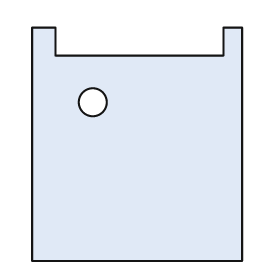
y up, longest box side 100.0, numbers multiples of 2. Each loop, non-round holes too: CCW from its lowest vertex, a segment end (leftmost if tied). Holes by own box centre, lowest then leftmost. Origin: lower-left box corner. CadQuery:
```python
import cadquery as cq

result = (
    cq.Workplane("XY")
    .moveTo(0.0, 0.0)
    .lineTo(90.0, 0.0)
    .lineTo(90.0, 100.0)
    .lineTo(82.0, 100.0)
    .lineTo(82.0, 88.0)
    .lineTo(10.0, 88.0)
    .lineTo(10.0, 100.0)
    .lineTo(0.0, 100.0)
    .close()
    .moveTo(26.0, 68.0)
    .circle(6.0)
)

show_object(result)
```